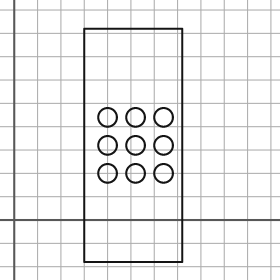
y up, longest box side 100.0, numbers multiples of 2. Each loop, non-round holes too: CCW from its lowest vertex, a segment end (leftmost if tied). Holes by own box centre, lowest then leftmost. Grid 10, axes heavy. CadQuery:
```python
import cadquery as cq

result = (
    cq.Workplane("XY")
    .moveTo(30.0, -18.0)
    .lineTo(72.0, -18.0)
    .lineTo(72.0, 82.0)
    .lineTo(30.0, 82.0)
    .close()
    .moveTo(40.0, 20.0)
    .circle(4.0)
    .moveTo(52.0, 20.0)
    .circle(4.0)
    .moveTo(64.0, 20.0)
    .circle(4.0)
    .moveTo(40.0, 32.0)
    .circle(4.0)
    .moveTo(52.0, 32.0)
    .circle(4.0)
    .moveTo(64.0, 32.0)
    .circle(4.0)
    .moveTo(40.0, 44.0)
    .circle(4.0)
    .moveTo(52.0, 44.0)
    .circle(4.0)
    .moveTo(64.0, 44.0)
    .circle(4.0)
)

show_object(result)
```